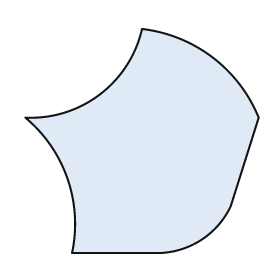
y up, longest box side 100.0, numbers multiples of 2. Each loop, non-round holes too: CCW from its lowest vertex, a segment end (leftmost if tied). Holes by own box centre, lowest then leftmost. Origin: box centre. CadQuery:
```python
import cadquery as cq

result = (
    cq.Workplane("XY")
    .moveTo(-30.0, -48.0)
    .lineTo(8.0, -48.0)
    .threePointArc((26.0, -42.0), (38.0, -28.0))
    .lineTo(50.0, 10.0)
    .threePointArc((30.0, 36.0), (0.0, 48.0))
    .threePointArc((-18.0, 20.0), (-50.0, 10.0))
    .threePointArc((-32.0, -16.0), (-30.0, -48.0))
    .close()
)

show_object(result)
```